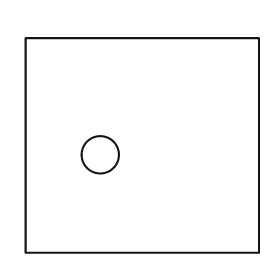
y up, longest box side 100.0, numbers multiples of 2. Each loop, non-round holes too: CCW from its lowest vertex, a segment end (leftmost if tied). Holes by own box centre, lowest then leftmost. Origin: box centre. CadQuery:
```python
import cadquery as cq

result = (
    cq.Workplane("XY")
    .moveTo(-50.0, -46.0)
    .lineTo(50.0, -46.0)
    .lineTo(50.0, 46.0)
    .lineTo(-50.0, 46.0)
    .close()
    .moveTo(-18.0, -4.0)
    .circle(8.0)
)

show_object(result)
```